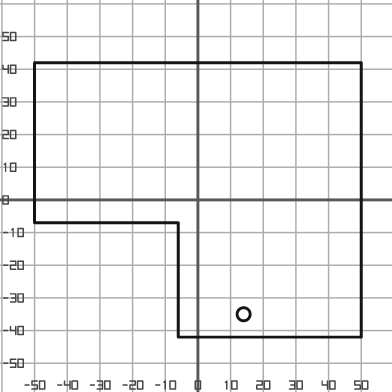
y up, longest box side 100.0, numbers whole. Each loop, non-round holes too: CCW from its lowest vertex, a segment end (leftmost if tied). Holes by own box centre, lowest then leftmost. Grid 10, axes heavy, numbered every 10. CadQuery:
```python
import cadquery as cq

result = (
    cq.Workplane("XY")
    .moveTo(-6.0, -42.0)
    .lineTo(50.0, -42.0)
    .lineTo(50.0, 42.0)
    .lineTo(-50.0, 42.0)
    .lineTo(-50.0, -7.0)
    .lineTo(-6.0, -7.0)
    .close()
    .moveTo(14.0, -35.0)
    .circle(2.0)
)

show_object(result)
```